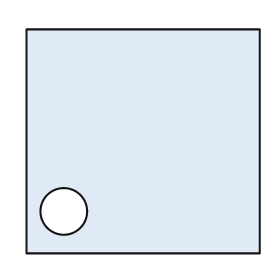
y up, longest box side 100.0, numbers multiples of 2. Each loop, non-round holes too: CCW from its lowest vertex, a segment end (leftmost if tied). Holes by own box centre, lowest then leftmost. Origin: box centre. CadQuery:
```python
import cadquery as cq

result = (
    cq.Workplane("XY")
    .moveTo(-50.0, -48.0)
    .lineTo(50.0, -48.0)
    .lineTo(50.0, 48.0)
    .lineTo(-50.0, 48.0)
    .close()
    .moveTo(-34.0, -30.0)
    .circle(10.0)
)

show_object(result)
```